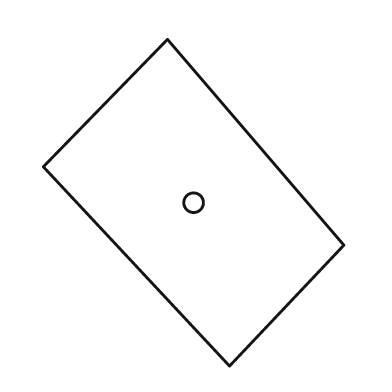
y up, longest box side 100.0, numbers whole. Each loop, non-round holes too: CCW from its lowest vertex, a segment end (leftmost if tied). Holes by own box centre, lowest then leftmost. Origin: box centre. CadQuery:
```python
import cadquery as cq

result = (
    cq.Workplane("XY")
    .moveTo(11.0, -50.0)
    .lineTo(46.0, -13.0)
    .lineTo(-8.0, 50.0)
    .lineTo(-46.0, 11.0)
    .close()
    .moveTo(0.0, 0.0)
    .circle(3.0)
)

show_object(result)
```